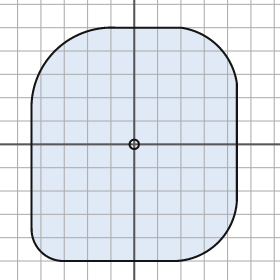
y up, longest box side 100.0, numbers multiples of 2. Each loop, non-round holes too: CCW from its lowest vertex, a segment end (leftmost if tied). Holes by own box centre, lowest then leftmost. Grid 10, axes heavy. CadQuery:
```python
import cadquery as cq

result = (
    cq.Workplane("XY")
    .moveTo(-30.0, -50.0)
    .lineTo(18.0, -50.0)
    .threePointArc((36.0, -42.0), (44.0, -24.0))
    .lineTo(44.0, 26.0)
    .threePointArc((36.0, 42.0), (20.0, 50.0))
    .lineTo(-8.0, 50.0)
    .threePointArc((-34.0, 40.0), (-44.0, 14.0))
    .lineTo(-44.0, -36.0)
    .threePointArc((-40.0, -46.0), (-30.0, -50.0))
    .close()
    .moveTo(0.0, 0.0)
    .circle(2.0)
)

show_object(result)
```